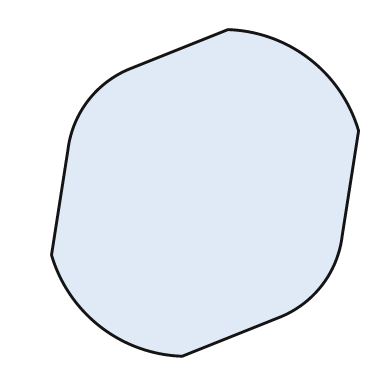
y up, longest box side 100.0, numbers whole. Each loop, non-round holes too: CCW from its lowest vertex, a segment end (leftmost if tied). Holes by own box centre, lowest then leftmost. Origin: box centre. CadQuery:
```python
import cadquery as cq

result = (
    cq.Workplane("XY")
    .moveTo(-7.0, -50.0)
    .lineTo(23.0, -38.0)
    .threePointArc((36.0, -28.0), (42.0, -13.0))
    .lineTo(47.0, 19.0)
    .threePointArc((32.0, 41.0), (7.0, 50.0))
    .lineTo(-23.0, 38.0)
    .threePointArc((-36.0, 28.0), (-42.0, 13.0))
    .lineTo(-47.0, -19.0)
    .threePointArc((-32.0, -41.0), (-7.0, -50.0))
    .close()
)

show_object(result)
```